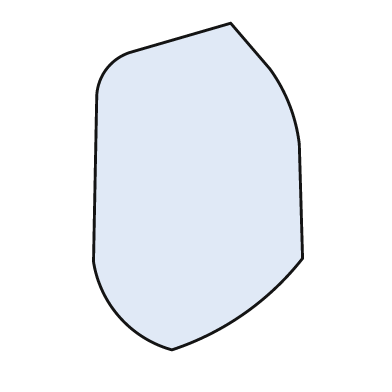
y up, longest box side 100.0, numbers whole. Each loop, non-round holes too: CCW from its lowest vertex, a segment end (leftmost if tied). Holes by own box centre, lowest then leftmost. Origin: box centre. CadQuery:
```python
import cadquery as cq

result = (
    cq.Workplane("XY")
    .moveTo(-8.0, -50.0)
    .threePointArc((14.0, -39.0), (32.0, -22.0))
    .lineTo(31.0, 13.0)
    .threePointArc((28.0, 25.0), (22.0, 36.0))
    .lineTo(10.0, 50.0)
    .lineTo(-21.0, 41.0)
    .threePointArc((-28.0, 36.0), (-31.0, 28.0))
    .lineTo(-32.0, -23.0)
    .threePointArc((-24.0, -40.0), (-8.0, -50.0))
    .close()
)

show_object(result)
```